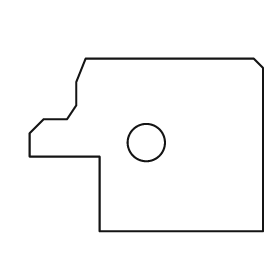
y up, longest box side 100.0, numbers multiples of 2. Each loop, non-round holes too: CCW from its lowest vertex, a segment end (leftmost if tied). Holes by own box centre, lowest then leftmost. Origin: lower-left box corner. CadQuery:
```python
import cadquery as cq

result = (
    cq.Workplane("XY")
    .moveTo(30.0, 0.0)
    .lineTo(100.0, 0.0)
    .lineTo(100.0, 70.0)
    .lineTo(96.0, 74.0)
    .lineTo(24.0, 74.0)
    .lineTo(20.0, 64.0)
    .lineTo(20.0, 54.0)
    .lineTo(16.0, 48.0)
    .lineTo(6.0, 48.0)
    .lineTo(0.0, 42.0)
    .lineTo(0.0, 32.0)
    .lineTo(30.0, 32.0)
    .close()
    .moveTo(50.0, 38.0)
    .circle(8.0)
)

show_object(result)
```